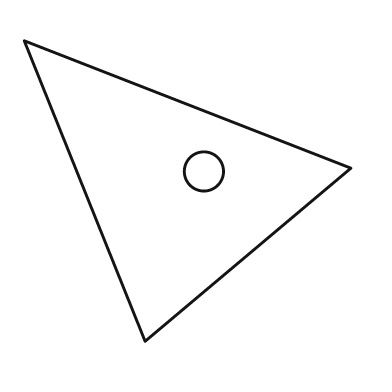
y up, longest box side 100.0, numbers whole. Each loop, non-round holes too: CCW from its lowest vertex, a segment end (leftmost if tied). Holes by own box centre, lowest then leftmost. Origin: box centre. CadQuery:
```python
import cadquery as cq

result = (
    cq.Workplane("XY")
    .moveTo(-13.0, -46.0)
    .lineTo(50.0, 7.0)
    .lineTo(-50.0, 46.0)
    .close()
    .moveTo(5.0, 6.0)
    .circle(6.0)
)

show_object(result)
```